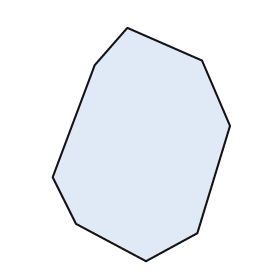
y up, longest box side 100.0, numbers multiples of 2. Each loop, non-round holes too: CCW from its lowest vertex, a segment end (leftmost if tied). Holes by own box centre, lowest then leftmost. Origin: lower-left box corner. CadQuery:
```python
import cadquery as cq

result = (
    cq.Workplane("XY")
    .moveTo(40.0, 0.0)
    .lineTo(62.0, 12.0)
    .lineTo(76.0, 58.0)
    .lineTo(64.0, 86.0)
    .lineTo(32.0, 100.0)
    .lineTo(18.0, 84.0)
    .lineTo(0.0, 36.0)
    .lineTo(10.0, 16.0)
    .close()
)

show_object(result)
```